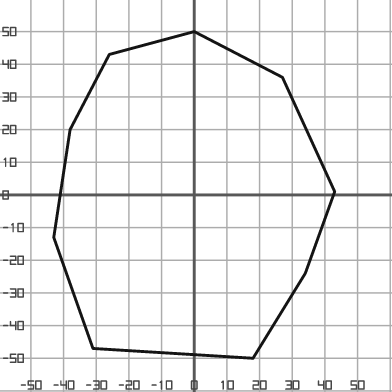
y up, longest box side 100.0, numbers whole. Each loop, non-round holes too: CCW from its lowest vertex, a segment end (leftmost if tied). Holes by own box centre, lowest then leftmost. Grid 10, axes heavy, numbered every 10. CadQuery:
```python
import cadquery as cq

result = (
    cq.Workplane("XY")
    .moveTo(18.0, -50.0)
    .lineTo(34.0, -24.0)
    .lineTo(43.0, 1.0)
    .lineTo(27.0, 36.0)
    .lineTo(0.0, 50.0)
    .lineTo(-26.0, 43.0)
    .lineTo(-38.0, 20.0)
    .lineTo(-43.0, -13.0)
    .lineTo(-31.0, -47.0)
    .close()
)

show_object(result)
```